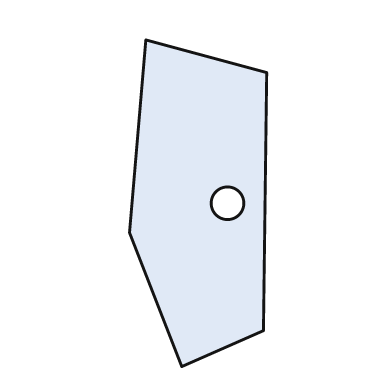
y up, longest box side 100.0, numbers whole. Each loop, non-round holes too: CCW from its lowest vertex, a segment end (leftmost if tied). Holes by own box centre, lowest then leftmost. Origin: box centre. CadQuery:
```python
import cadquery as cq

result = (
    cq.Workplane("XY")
    .moveTo(-5.0, -50.0)
    .lineTo(20.0, -39.0)
    .lineTo(21.0, 40.0)
    .lineTo(-16.0, 50.0)
    .lineTo(-21.0, -9.0)
    .close()
    .moveTo(9.0, 0.0)
    .circle(5.0)
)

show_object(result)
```